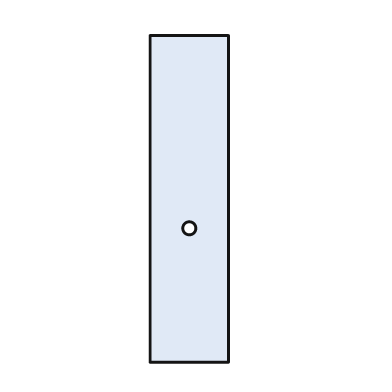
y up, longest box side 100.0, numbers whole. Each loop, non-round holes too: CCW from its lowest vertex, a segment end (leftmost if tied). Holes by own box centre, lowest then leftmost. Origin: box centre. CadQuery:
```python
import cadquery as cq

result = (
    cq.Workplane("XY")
    .moveTo(-12.0, -50.0)
    .lineTo(12.0, -50.0)
    .lineTo(12.0, 50.0)
    .lineTo(-12.0, 50.0)
    .close()
    .moveTo(0.0, -9.0)
    .circle(2.0)
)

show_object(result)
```